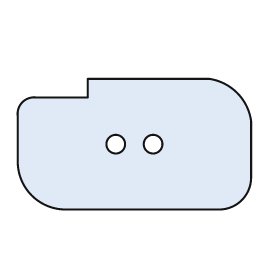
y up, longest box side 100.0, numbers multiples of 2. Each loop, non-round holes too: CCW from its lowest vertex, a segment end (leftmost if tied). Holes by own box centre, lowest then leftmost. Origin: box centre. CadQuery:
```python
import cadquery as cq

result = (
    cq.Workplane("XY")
    .moveTo(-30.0, -28.0)
    .lineTo(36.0, -28.0)
    .threePointArc((46.0, -24.0), (50.0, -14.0))
    .lineTo(50.0, 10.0)
    .threePointArc((44.0, 22.0), (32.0, 28.0))
    .lineTo(-20.0, 28.0)
    .lineTo(-20.0, 20.0)
    .lineTo(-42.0, 20.0)
    .threePointArc((-48.0, 18.0), (-50.0, 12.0))
    .lineTo(-50.0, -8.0)
    .threePointArc((-44.0, -22.0), (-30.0, -28.0))
    .close()
    .moveTo(-8.0, 0.0)
    .circle(4.0)
    .moveTo(8.0, 0.0)
    .circle(4.0)
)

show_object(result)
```